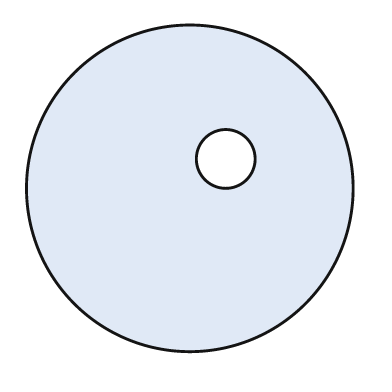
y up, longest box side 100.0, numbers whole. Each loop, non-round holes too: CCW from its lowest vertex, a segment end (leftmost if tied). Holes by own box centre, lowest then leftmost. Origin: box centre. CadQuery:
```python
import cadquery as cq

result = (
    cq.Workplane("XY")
    .moveTo(0.0, 0.0)
    .circle(50.0)
    .moveTo(11.0, 9.0)
    .circle(9.0)
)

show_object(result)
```